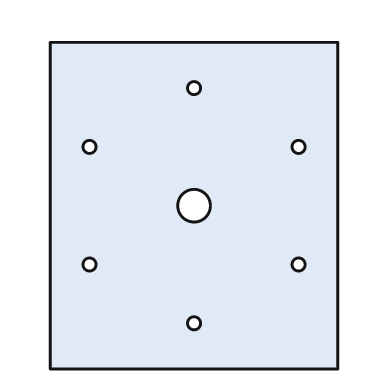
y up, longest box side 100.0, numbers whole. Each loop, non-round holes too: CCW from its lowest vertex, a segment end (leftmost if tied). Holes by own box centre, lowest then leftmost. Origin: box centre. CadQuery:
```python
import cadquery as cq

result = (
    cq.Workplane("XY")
    .moveTo(-44.0, -50.0)
    .lineTo(44.0, -50.0)
    .lineTo(44.0, 50.0)
    .lineTo(-44.0, 50.0)
    .close()
    .moveTo(0.0, -36.0)
    .circle(2.0)
    .moveTo(-32.0, -18.0)
    .circle(2.0)
    .moveTo(32.0, -18.0)
    .circle(2.0)
    .moveTo(0.0, 0.0)
    .circle(5.0)
    .moveTo(-32.0, 18.0)
    .circle(2.0)
    .moveTo(32.0, 18.0)
    .circle(2.0)
    .moveTo(0.0, 36.0)
    .circle(2.0)
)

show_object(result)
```